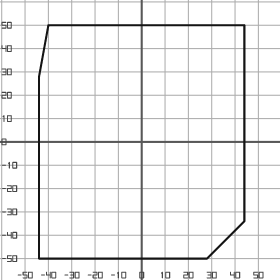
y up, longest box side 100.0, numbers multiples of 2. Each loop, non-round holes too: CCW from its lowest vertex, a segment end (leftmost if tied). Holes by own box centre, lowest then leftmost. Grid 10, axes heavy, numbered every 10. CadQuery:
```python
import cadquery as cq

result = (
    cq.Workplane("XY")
    .moveTo(-44.0, -50.0)
    .lineTo(28.0, -50.0)
    .lineTo(44.0, -34.0)
    .lineTo(44.0, 50.0)
    .lineTo(-40.0, 50.0)
    .lineTo(-44.0, 28.0)
    .close()
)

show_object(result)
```